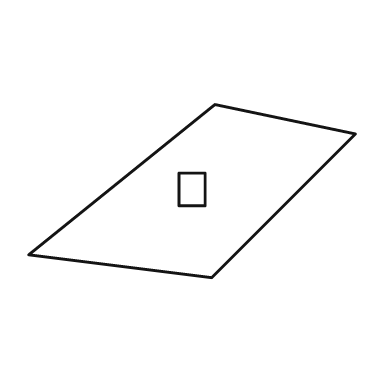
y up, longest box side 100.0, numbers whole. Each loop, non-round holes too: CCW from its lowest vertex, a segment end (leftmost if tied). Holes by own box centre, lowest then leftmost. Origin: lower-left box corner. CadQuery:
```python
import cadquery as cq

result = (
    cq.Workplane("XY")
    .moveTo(56.0, 0.0)
    .lineTo(100.0, 44.0)
    .lineTo(57.0, 53.0)
    .lineTo(0.0, 7.0)
    .close()
    .moveTo(46.0, 22.0)
    .lineTo(54.0, 22.0)
    .lineTo(54.0, 32.0)
    .lineTo(46.0, 32.0)
    .close()
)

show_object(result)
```